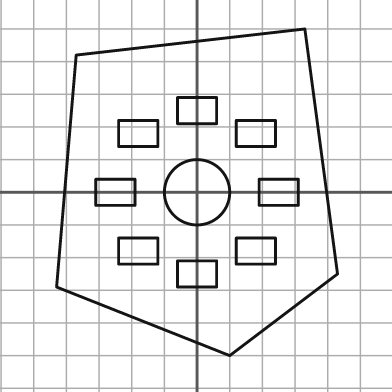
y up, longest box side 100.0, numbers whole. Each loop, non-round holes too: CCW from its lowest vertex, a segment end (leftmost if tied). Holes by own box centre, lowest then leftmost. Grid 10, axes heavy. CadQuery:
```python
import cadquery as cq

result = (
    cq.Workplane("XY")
    .moveTo(10.0, -50.0)
    .lineTo(43.0, -25.0)
    .lineTo(33.0, 50.0)
    .lineTo(-37.0, 42.0)
    .lineTo(-43.0, -29.0)
    .close()
    .moveTo(-6.0, -29.0)
    .lineTo(6.0, -29.0)
    .lineTo(6.0, -21.0)
    .lineTo(-6.0, -21.0)
    .close()
    .moveTo(-24.0, -22.0)
    .lineTo(-12.0, -22.0)
    .lineTo(-12.0, -14.0)
    .lineTo(-24.0, -14.0)
    .close()
    .moveTo(12.0, -22.0)
    .lineTo(24.0, -22.0)
    .lineTo(24.0, -14.0)
    .lineTo(12.0, -14.0)
    .close()
    .moveTo(-31.0, -4.0)
    .lineTo(-19.0, -4.0)
    .lineTo(-19.0, 4.0)
    .lineTo(-31.0, 4.0)
    .close()
    .moveTo(0.0, 0.0)
    .circle(10.0)
    .moveTo(19.0, -4.0)
    .lineTo(31.0, -4.0)
    .lineTo(31.0, 4.0)
    .lineTo(19.0, 4.0)
    .close()
    .moveTo(-24.0, 14.0)
    .lineTo(-12.0, 14.0)
    .lineTo(-12.0, 22.0)
    .lineTo(-24.0, 22.0)
    .close()
    .moveTo(12.0, 14.0)
    .lineTo(24.0, 14.0)
    .lineTo(24.0, 22.0)
    .lineTo(12.0, 22.0)
    .close()
    .moveTo(-6.0, 21.0)
    .lineTo(6.0, 21.0)
    .lineTo(6.0, 29.0)
    .lineTo(-6.0, 29.0)
    .close()
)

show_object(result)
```